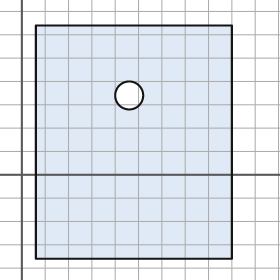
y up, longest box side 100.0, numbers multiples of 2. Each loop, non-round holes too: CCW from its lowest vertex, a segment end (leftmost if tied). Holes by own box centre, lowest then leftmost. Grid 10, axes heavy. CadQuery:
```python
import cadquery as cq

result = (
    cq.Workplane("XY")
    .moveTo(6.0, -36.0)
    .lineTo(90.0, -36.0)
    .lineTo(90.0, 64.0)
    .lineTo(6.0, 64.0)
    .close()
    .moveTo(46.0, 34.0)
    .circle(6.0)
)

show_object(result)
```